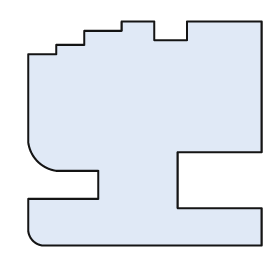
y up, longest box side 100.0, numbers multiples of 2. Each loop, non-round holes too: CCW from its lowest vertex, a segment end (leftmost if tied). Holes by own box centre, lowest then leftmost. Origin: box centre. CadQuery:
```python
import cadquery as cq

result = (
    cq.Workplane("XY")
    .moveTo(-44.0, -48.0)
    .lineTo(50.0, -48.0)
    .lineTo(50.0, -32.0)
    .lineTo(14.0, -32.0)
    .lineTo(14.0, -8.0)
    .lineTo(50.0, -8.0)
    .lineTo(50.0, 48.0)
    .lineTo(18.0, 48.0)
    .lineTo(18.0, 40.0)
    .lineTo(4.0, 40.0)
    .lineTo(4.0, 48.0)
    .lineTo(-10.0, 48.0)
    .lineTo(-10.0, 44.0)
    .lineTo(-26.0, 44.0)
    .lineTo(-26.0, 38.0)
    .lineTo(-38.0, 38.0)
    .lineTo(-38.0, 34.0)
    .lineTo(-50.0, 34.0)
    .lineTo(-50.0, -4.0)
    .threePointArc((-46.0, -12.0), (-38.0, -16.0))
    .lineTo(-20.0, -16.0)
    .lineTo(-20.0, -28.0)
    .lineTo(-50.0, -28.0)
    .lineTo(-50.0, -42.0)
    .threePointArc((-48.0, -46.0), (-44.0, -48.0))
    .close()
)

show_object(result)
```